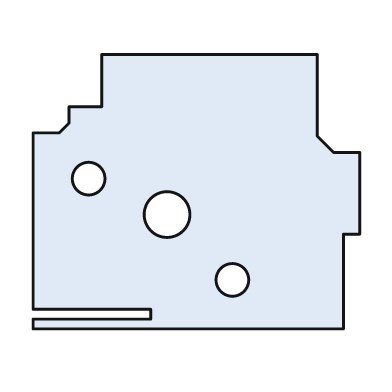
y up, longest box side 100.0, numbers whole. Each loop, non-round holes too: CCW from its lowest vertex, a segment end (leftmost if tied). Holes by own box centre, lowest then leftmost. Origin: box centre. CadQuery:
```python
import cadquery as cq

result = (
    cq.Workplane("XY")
    .moveTo(-50.0, -42.0)
    .lineTo(45.0, -42.0)
    .lineTo(45.0, -13.0)
    .lineTo(50.0, -13.0)
    .lineTo(50.0, 12.0)
    .lineTo(42.0, 12.0)
    .lineTo(37.0, 17.0)
    .lineTo(37.0, 42.0)
    .lineTo(-29.0, 42.0)
    .lineTo(-29.0, 26.0)
    .lineTo(-39.0, 26.0)
    .lineTo(-39.0, 21.0)
    .lineTo(-42.0, 18.0)
    .lineTo(-50.0, 18.0)
    .lineTo(-50.0, -36.0)
    .lineTo(-14.0, -36.0)
    .lineTo(-14.0, -39.0)
    .lineTo(-50.0, -39.0)
    .close()
    .moveTo(11.0, -27.0)
    .circle(5.0)
    .moveTo(-9.0, -7.0)
    .circle(7.0)
    .moveTo(-33.0, 4.0)
    .circle(5.0)
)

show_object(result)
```